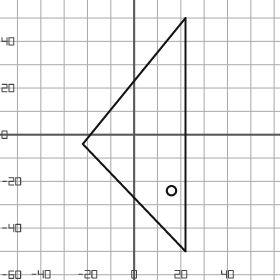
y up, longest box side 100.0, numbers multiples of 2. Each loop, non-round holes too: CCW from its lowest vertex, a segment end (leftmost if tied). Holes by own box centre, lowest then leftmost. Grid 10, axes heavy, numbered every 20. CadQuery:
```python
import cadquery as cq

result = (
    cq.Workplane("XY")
    .moveTo(22.0, -50.0)
    .lineTo(22.0, 50.0)
    .lineTo(-22.0, -4.0)
    .close()
    .moveTo(16.0, -24.0)
    .circle(2.0)
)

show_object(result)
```